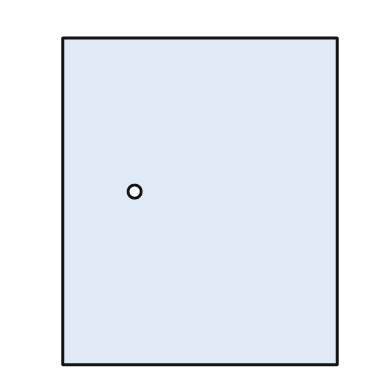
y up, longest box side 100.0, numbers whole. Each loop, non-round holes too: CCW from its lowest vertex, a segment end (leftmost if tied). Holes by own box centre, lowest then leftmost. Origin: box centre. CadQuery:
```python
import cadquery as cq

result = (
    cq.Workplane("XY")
    .moveTo(-42.0, -50.0)
    .lineTo(42.0, -50.0)
    .lineTo(42.0, 50.0)
    .lineTo(-42.0, 50.0)
    .close()
    .moveTo(-20.0, 3.0)
    .circle(2.0)
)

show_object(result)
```